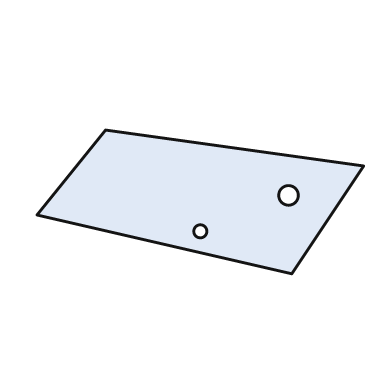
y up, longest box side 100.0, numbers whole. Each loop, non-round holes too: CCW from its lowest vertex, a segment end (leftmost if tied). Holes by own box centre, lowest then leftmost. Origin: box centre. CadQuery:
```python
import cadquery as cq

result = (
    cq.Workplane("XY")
    .moveTo(28.0, -22.0)
    .lineTo(50.0, 11.0)
    .lineTo(-29.0, 22.0)
    .lineTo(-50.0, -4.0)
    .close()
    .moveTo(0.0, -9.0)
    .circle(2.0)
    .moveTo(27.0, 2.0)
    .circle(3.0)
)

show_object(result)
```